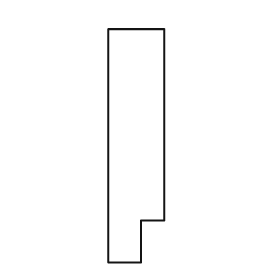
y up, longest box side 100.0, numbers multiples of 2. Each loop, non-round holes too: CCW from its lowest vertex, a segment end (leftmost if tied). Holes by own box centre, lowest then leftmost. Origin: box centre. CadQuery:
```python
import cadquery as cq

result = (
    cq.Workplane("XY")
    .moveTo(-12.0, -50.0)
    .lineTo(2.0, -50.0)
    .lineTo(2.0, -32.0)
    .lineTo(12.0, -32.0)
    .lineTo(12.0, 50.0)
    .lineTo(-12.0, 50.0)
    .close()
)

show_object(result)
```